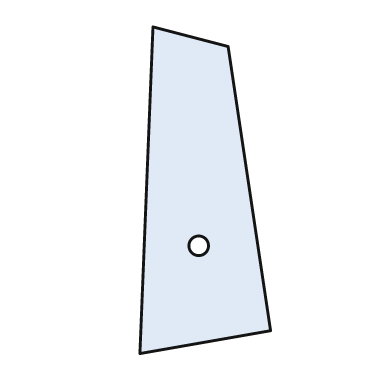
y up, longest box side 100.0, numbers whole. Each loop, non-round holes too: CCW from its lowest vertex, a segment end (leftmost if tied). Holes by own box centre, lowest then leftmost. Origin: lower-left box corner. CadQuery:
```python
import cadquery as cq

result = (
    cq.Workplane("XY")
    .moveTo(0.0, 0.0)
    .lineTo(40.0, 7.0)
    .lineTo(27.0, 94.0)
    .lineTo(4.0, 100.0)
    .close()
    .moveTo(18.0, 33.0)
    .circle(3.0)
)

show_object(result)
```